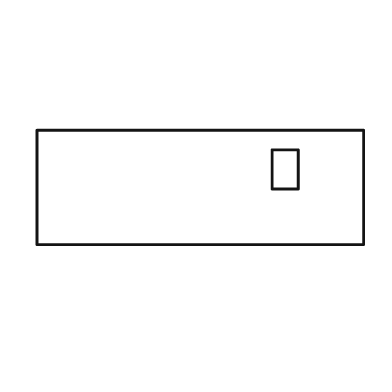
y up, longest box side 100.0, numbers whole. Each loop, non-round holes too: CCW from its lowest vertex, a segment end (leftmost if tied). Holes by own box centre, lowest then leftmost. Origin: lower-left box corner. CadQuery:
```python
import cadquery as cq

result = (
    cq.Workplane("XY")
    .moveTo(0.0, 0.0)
    .lineTo(100.0, 0.0)
    .lineTo(100.0, 35.0)
    .lineTo(0.0, 35.0)
    .close()
    .moveTo(72.0, 17.0)
    .lineTo(80.0, 17.0)
    .lineTo(80.0, 29.0)
    .lineTo(72.0, 29.0)
    .close()
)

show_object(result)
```